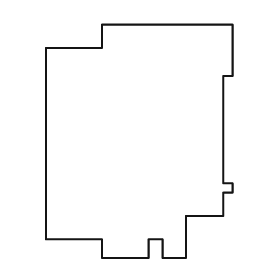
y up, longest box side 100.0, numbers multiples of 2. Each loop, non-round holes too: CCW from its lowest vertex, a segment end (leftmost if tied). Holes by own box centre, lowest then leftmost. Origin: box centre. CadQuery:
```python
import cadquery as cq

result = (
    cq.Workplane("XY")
    .moveTo(-16.0, -50.0)
    .lineTo(4.0, -50.0)
    .lineTo(4.0, -42.0)
    .lineTo(10.0, -42.0)
    .lineTo(10.0, -50.0)
    .lineTo(20.0, -50.0)
    .lineTo(20.0, -32.0)
    .lineTo(36.0, -32.0)
    .lineTo(36.0, -22.0)
    .lineTo(40.0, -22.0)
    .lineTo(40.0, -18.0)
    .lineTo(36.0, -18.0)
    .lineTo(36.0, 28.0)
    .lineTo(40.0, 28.0)
    .lineTo(40.0, 50.0)
    .lineTo(-16.0, 50.0)
    .lineTo(-16.0, 40.0)
    .lineTo(-40.0, 40.0)
    .lineTo(-40.0, -42.0)
    .lineTo(-16.0, -42.0)
    .close()
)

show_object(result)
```